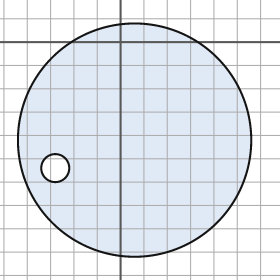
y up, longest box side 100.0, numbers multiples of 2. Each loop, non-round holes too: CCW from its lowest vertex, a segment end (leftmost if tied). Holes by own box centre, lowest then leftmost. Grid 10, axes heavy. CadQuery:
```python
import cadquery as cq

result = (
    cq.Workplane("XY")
    .moveTo(6.0, -42.0)
    .circle(50.0)
    .moveTo(-28.0, -54.0)
    .circle(6.0)
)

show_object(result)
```